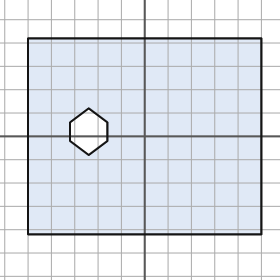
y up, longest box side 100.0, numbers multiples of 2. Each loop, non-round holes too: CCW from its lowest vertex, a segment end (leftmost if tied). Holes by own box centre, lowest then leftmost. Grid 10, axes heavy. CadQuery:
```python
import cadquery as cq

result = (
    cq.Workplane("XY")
    .moveTo(-50.0, -42.0)
    .lineTo(50.0, -42.0)
    .lineTo(50.0, 42.0)
    .lineTo(-50.0, 42.0)
    .close()
    .moveTo(-24.0, -8.0)
    .lineTo(-16.0, -2.0)
    .lineTo(-16.0, 6.0)
    .lineTo(-24.0, 12.0)
    .lineTo(-32.0, 6.0)
    .lineTo(-32.0, -2.0)
    .close()
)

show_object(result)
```